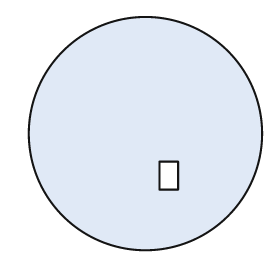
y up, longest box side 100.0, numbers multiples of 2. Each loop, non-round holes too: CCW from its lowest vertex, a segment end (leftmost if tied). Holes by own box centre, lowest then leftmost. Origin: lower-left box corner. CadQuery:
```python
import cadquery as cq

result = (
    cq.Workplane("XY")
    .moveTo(50.0, 50.0)
    .circle(50.0)
    .moveTo(56.0, 26.0)
    .lineTo(64.0, 26.0)
    .lineTo(64.0, 38.0)
    .lineTo(56.0, 38.0)
    .close()
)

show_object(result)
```